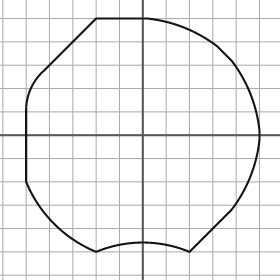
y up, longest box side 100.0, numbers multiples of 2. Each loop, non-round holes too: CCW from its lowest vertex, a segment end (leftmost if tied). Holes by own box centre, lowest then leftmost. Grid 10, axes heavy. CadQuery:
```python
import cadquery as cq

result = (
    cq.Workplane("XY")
    .moveTo(-20.0, -50.0)
    .threePointArc((0.0, -46.0), (20.0, -50.0))
    .lineTo(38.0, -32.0)
    .threePointArc((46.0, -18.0), (50.0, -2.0))
    .lineTo(50.0, 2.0)
    .threePointArc((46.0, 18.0), (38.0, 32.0))
    .lineTo(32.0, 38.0)
    .threePointArc((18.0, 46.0), (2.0, 50.0))
    .lineTo(-20.0, 50.0)
    .lineTo(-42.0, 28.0)
    .threePointArc((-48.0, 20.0), (-50.0, 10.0))
    .lineTo(-50.0, -20.0)
    .threePointArc((-38.0, -38.0), (-20.0, -50.0))
    .close()
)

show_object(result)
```